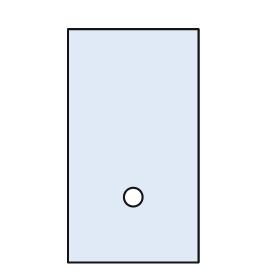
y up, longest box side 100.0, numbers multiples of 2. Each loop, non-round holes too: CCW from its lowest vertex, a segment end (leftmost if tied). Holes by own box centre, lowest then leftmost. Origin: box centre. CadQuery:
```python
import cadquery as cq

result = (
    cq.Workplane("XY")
    .moveTo(-28.0, -50.0)
    .lineTo(28.0, -50.0)
    .lineTo(28.0, 50.0)
    .lineTo(-28.0, 50.0)
    .close()
    .moveTo(0.0, -22.0)
    .circle(4.0)
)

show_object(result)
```